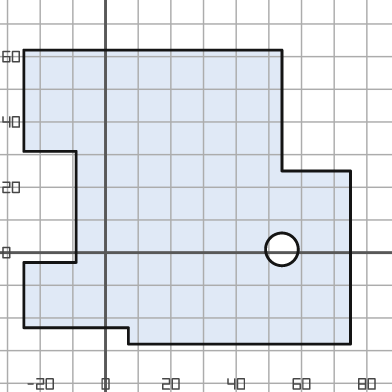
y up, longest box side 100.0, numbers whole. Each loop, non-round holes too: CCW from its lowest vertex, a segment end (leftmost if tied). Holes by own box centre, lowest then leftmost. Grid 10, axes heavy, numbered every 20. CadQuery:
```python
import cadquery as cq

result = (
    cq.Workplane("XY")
    .moveTo(7.0, -28.0)
    .lineTo(75.0, -28.0)
    .lineTo(75.0, 25.0)
    .lineTo(54.0, 25.0)
    .lineTo(54.0, 62.0)
    .lineTo(-25.0, 62.0)
    .lineTo(-25.0, 31.0)
    .lineTo(-9.0, 31.0)
    .lineTo(-9.0, -3.0)
    .lineTo(-25.0, -3.0)
    .lineTo(-25.0, -23.0)
    .lineTo(7.0, -23.0)
    .close()
    .moveTo(54.0, 1.0)
    .circle(5.0)
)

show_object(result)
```